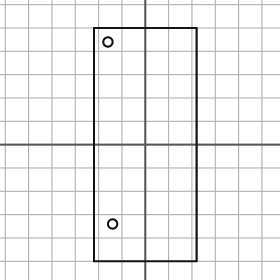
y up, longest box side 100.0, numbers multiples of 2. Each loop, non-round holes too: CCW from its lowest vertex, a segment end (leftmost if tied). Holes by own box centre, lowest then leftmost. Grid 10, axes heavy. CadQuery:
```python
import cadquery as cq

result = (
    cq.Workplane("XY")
    .moveTo(-22.0, -50.0)
    .lineTo(22.0, -50.0)
    .lineTo(22.0, 50.0)
    .lineTo(-22.0, 50.0)
    .close()
    .moveTo(-14.0, -34.0)
    .circle(2.0)
    .moveTo(-16.0, 44.0)
    .circle(2.0)
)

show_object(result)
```